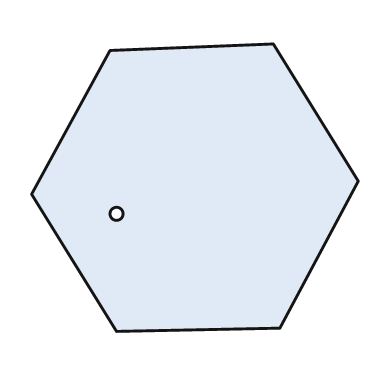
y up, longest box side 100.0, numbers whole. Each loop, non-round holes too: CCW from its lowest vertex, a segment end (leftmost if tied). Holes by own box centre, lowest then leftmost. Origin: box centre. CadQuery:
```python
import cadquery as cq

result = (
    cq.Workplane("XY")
    .moveTo(-24.0, -44.0)
    .lineTo(26.0, -43.0)
    .lineTo(50.0, 2.0)
    .lineTo(24.0, 44.0)
    .lineTo(-26.0, 42.0)
    .lineTo(-50.0, -2.0)
    .close()
    .moveTo(-24.0, -8.0)
    .circle(2.0)
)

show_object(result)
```